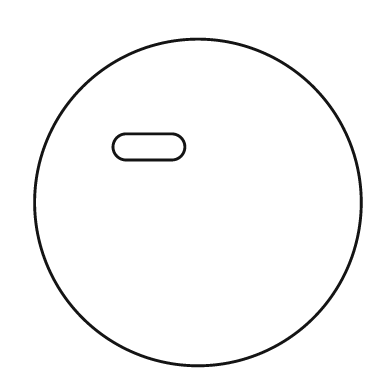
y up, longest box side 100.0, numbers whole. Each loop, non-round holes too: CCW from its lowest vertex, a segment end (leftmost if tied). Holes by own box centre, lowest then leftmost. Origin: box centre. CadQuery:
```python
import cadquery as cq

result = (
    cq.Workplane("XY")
    .moveTo(0.0, 0.0)
    .circle(50.0)
    .moveTo(-22.0, 13.0)
    .lineTo(-8.0, 13.0)
    .threePointArc((-4.0, 17.0), (-8.0, 21.0))
    .lineTo(-22.0, 21.0)
    .threePointArc((-26.0, 17.0), (-22.0, 13.0))
    .close()
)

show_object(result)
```